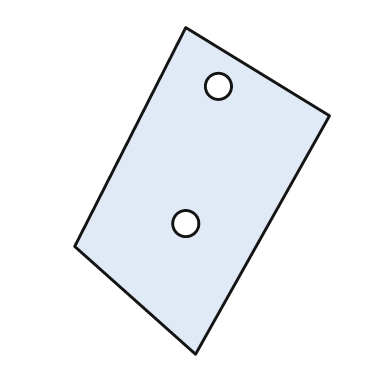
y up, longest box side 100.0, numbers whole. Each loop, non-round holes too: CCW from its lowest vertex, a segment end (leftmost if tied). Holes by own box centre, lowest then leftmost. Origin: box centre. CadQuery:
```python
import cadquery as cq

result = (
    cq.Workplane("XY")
    .moveTo(-2.0, -50.0)
    .lineTo(39.0, 23.0)
    .lineTo(-5.0, 50.0)
    .lineTo(-39.0, -17.0)
    .close()
    .moveTo(-5.0, -10.0)
    .circle(4.0)
    .moveTo(5.0, 32.0)
    .circle(4.0)
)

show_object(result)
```